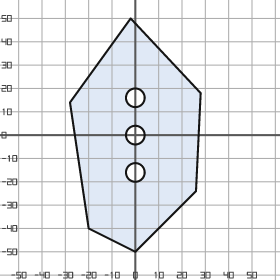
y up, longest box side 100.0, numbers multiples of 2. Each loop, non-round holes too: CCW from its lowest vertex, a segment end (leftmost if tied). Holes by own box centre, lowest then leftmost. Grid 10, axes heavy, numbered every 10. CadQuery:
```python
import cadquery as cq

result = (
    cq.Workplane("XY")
    .moveTo(0.0, -50.0)
    .lineTo(26.0, -24.0)
    .lineTo(28.0, 18.0)
    .lineTo(-2.0, 50.0)
    .lineTo(-28.0, 14.0)
    .lineTo(-20.0, -40.0)
    .close()
    .moveTo(0.0, -16.0)
    .circle(4.0)
    .moveTo(0.0, 0.0)
    .circle(4.0)
    .moveTo(0.0, 16.0)
    .circle(4.0)
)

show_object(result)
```